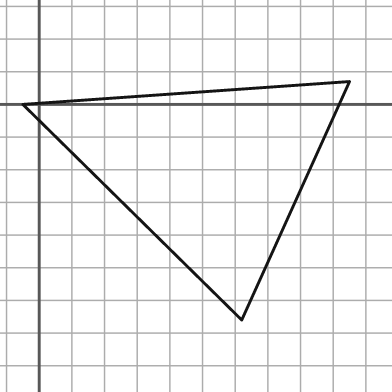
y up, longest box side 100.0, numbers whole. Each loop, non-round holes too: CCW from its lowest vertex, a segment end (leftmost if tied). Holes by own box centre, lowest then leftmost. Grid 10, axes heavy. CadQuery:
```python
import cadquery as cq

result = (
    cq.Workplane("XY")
    .moveTo(62.0, -66.0)
    .lineTo(95.0, 7.0)
    .lineTo(-5.0, 0.0)
    .close()
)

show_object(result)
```